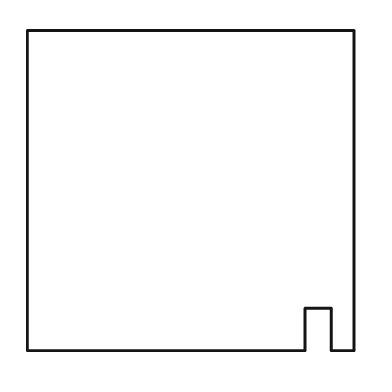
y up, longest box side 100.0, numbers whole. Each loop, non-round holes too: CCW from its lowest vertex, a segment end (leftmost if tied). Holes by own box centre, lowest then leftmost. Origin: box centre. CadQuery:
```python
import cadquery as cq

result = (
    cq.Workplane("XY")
    .moveTo(-50.0, -49.0)
    .lineTo(35.0, -49.0)
    .lineTo(35.0, -36.0)
    .lineTo(43.0, -36.0)
    .lineTo(43.0, -49.0)
    .lineTo(50.0, -49.0)
    .lineTo(50.0, 49.0)
    .lineTo(-50.0, 49.0)
    .close()
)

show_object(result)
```